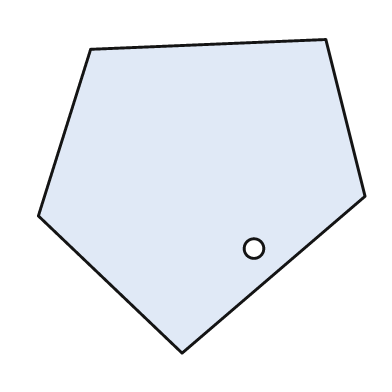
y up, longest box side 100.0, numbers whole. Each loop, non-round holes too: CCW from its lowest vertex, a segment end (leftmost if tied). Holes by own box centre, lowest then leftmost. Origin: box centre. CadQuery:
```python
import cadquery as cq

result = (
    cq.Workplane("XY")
    .moveTo(-6.0, -48.0)
    .lineTo(50.0, 0.0)
    .lineTo(38.0, 48.0)
    .lineTo(-34.0, 45.0)
    .lineTo(-50.0, -6.0)
    .close()
    .moveTo(16.0, -16.0)
    .circle(3.0)
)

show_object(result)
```